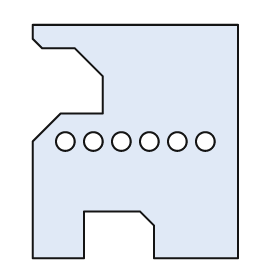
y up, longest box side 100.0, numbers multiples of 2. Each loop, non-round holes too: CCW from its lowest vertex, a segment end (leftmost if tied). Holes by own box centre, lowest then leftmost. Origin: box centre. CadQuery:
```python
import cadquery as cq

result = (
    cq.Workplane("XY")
    .moveTo(-44.0, -50.0)
    .lineTo(-22.0, -50.0)
    .lineTo(-22.0, -30.0)
    .lineTo(2.0, -30.0)
    .lineTo(8.0, -36.0)
    .lineTo(8.0, -50.0)
    .lineTo(44.0, -50.0)
    .lineTo(44.0, 50.0)
    .lineTo(-44.0, 50.0)
    .lineTo(-44.0, 44.0)
    .lineTo(-40.0, 40.0)
    .lineTo(-26.0, 40.0)
    .lineTo(-14.0, 28.0)
    .lineTo(-14.0, 12.0)
    .lineTo(-32.0, 12.0)
    .lineTo(-44.0, 0.0)
    .close()
    .moveTo(-30.0, 0.0)
    .circle(4.0)
    .moveTo(-18.0, 0.0)
    .circle(4.0)
    .moveTo(-6.0, 0.0)
    .circle(4.0)
    .moveTo(6.0, 0.0)
    .circle(4.0)
    .moveTo(18.0, 0.0)
    .circle(4.0)
    .moveTo(30.0, 0.0)
    .circle(4.0)
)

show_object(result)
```